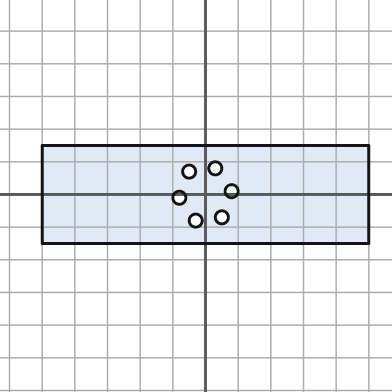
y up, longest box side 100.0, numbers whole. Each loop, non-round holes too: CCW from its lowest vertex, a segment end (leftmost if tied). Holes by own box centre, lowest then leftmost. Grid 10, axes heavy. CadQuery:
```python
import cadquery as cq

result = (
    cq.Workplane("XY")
    .moveTo(-50.0, -15.0)
    .lineTo(50.0, -15.0)
    .lineTo(50.0, 15.0)
    .lineTo(-50.0, 15.0)
    .close()
    .moveTo(-3.0, -8.0)
    .circle(2.0)
    .moveTo(5.0, -7.0)
    .circle(2.0)
    .moveTo(-8.0, -1.0)
    .circle(2.0)
    .moveTo(8.0, 1.0)
    .circle(2.0)
    .moveTo(-5.0, 7.0)
    .circle(2.0)
    .moveTo(3.0, 8.0)
    .circle(2.0)
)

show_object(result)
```